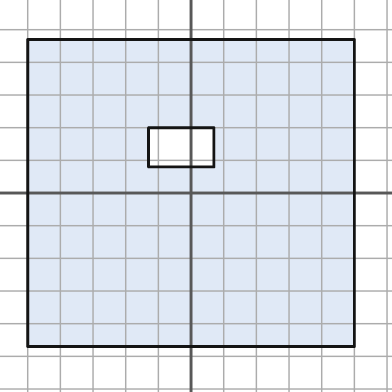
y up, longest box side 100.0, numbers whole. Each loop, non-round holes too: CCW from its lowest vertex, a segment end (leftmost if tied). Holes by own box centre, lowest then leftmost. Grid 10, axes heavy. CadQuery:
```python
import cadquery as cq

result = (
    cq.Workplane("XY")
    .moveTo(-50.0, -47.0)
    .lineTo(50.0, -47.0)
    .lineTo(50.0, 47.0)
    .lineTo(-50.0, 47.0)
    .close()
    .moveTo(-13.0, 8.0)
    .lineTo(7.0, 8.0)
    .lineTo(7.0, 20.0)
    .lineTo(-13.0, 20.0)
    .close()
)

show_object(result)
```